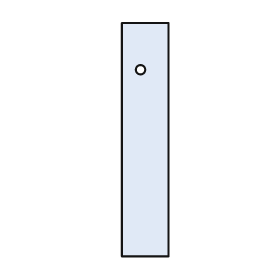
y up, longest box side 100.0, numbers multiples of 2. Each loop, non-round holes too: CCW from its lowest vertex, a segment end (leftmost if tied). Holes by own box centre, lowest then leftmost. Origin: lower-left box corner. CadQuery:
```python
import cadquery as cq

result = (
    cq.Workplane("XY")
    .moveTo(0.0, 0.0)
    .lineTo(20.0, 0.0)
    .lineTo(20.0, 100.0)
    .lineTo(0.0, 100.0)
    .close()
    .moveTo(8.0, 80.0)
    .circle(2.0)
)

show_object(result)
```